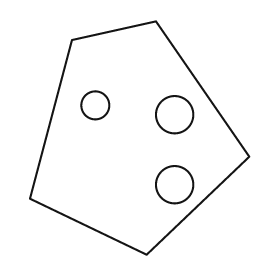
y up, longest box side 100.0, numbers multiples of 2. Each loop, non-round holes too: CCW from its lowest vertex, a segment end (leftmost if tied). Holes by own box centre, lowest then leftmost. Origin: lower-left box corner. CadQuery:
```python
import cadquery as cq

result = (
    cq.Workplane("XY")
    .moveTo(50.0, 0.0)
    .lineTo(94.0, 42.0)
    .lineTo(54.0, 100.0)
    .lineTo(18.0, 92.0)
    .lineTo(0.0, 24.0)
    .close()
    .moveTo(62.0, 30.0)
    .circle(8.0)
    .moveTo(62.0, 60.0)
    .circle(8.0)
    .moveTo(28.0, 64.0)
    .circle(6.0)
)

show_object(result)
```